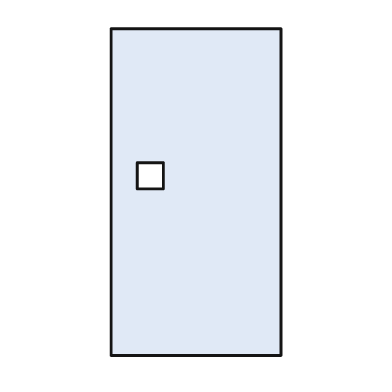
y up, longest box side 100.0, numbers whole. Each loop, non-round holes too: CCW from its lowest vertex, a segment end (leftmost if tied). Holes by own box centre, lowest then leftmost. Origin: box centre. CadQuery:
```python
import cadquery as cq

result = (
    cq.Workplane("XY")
    .moveTo(-26.0, -50.0)
    .lineTo(26.0, -50.0)
    .lineTo(26.0, 50.0)
    .lineTo(-26.0, 50.0)
    .close()
    .moveTo(-18.0, 1.0)
    .lineTo(-10.0, 1.0)
    .lineTo(-10.0, 9.0)
    .lineTo(-18.0, 9.0)
    .close()
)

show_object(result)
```